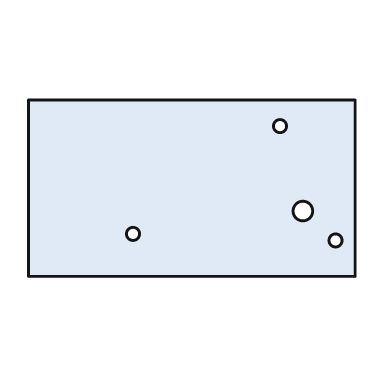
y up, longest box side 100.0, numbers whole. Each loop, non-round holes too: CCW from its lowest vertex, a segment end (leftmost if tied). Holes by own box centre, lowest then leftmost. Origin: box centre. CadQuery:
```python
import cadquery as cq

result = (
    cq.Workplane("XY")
    .moveTo(-50.0, -27.0)
    .lineTo(50.0, -27.0)
    .lineTo(50.0, 27.0)
    .lineTo(-50.0, 27.0)
    .close()
    .moveTo(44.0, -16.0)
    .circle(2.0)
    .moveTo(-18.0, -14.0)
    .circle(2.0)
    .moveTo(34.0, -7.0)
    .circle(3.0)
    .moveTo(27.0, 19.0)
    .circle(2.0)
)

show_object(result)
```